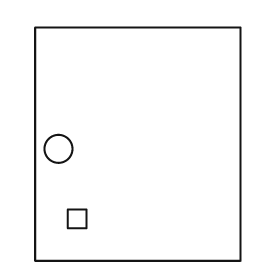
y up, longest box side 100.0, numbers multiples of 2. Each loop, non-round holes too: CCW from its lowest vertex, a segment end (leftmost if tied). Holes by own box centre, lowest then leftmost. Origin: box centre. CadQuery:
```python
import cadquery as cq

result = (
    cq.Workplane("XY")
    .moveTo(-44.0, -50.0)
    .lineTo(44.0, -50.0)
    .lineTo(44.0, 50.0)
    .lineTo(-44.0, 50.0)
    .close()
    .moveTo(-30.0, -36.0)
    .lineTo(-22.0, -36.0)
    .lineTo(-22.0, -28.0)
    .lineTo(-30.0, -28.0)
    .close()
    .moveTo(-34.0, -2.0)
    .circle(6.0)
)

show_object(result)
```